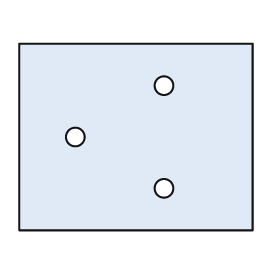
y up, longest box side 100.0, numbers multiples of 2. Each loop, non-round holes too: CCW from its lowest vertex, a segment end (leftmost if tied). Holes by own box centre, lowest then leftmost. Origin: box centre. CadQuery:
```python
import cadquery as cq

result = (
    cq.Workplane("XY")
    .moveTo(-50.0, -40.0)
    .lineTo(50.0, -40.0)
    .lineTo(50.0, 40.0)
    .lineTo(-50.0, 40.0)
    .close()
    .moveTo(12.0, -22.0)
    .circle(4.0)
    .moveTo(-26.0, 0.0)
    .circle(4.0)
    .moveTo(12.0, 22.0)
    .circle(4.0)
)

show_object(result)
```